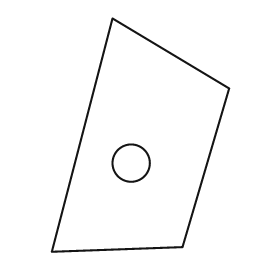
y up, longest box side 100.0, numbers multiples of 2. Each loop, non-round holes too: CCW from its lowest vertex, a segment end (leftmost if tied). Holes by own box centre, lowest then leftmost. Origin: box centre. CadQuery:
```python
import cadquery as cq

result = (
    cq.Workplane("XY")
    .moveTo(-38.0, -50.0)
    .lineTo(18.0, -48.0)
    .lineTo(38.0, 20.0)
    .lineTo(-12.0, 50.0)
    .close()
    .moveTo(-4.0, -12.0)
    .circle(8.0)
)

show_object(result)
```